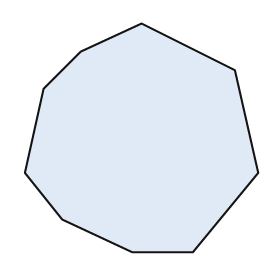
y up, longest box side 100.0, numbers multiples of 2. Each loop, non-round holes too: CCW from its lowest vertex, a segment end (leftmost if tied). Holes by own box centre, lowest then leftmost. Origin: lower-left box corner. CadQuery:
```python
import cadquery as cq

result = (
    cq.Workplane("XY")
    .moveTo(46.0, 0.0)
    .lineTo(72.0, 0.0)
    .lineTo(100.0, 34.0)
    .lineTo(90.0, 78.0)
    .lineTo(50.0, 98.0)
    .lineTo(24.0, 86.0)
    .lineTo(8.0, 70.0)
    .lineTo(0.0, 34.0)
    .lineTo(16.0, 14.0)
    .close()
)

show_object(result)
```